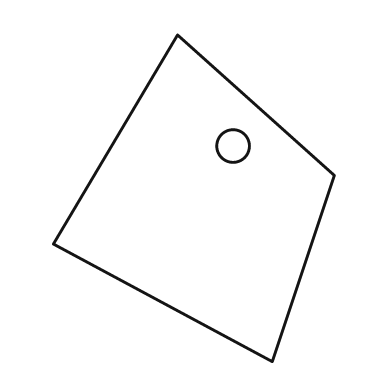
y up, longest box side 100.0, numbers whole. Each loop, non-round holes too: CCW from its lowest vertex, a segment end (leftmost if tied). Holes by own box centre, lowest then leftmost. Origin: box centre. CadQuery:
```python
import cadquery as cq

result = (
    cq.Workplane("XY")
    .moveTo(24.0, -50.0)
    .lineTo(43.0, 7.0)
    .lineTo(-5.0, 50.0)
    .lineTo(-43.0, -14.0)
    .close()
    .moveTo(12.0, 16.0)
    .circle(5.0)
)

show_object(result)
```